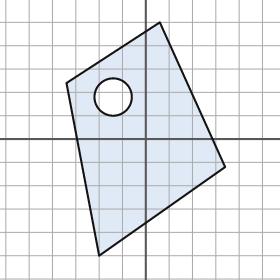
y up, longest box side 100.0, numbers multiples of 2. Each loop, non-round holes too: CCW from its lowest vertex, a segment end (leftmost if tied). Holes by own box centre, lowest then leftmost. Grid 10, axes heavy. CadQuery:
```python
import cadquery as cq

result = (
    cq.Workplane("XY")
    .moveTo(-20.0, -50.0)
    .lineTo(34.0, -12.0)
    .lineTo(6.0, 50.0)
    .lineTo(-34.0, 24.0)
    .close()
    .moveTo(-14.0, 18.0)
    .circle(8.0)
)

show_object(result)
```